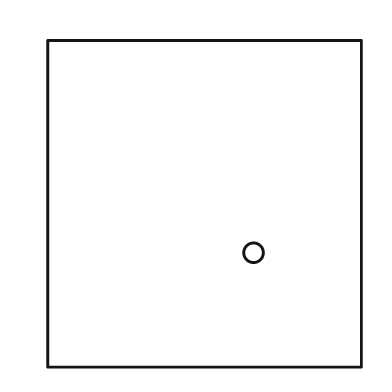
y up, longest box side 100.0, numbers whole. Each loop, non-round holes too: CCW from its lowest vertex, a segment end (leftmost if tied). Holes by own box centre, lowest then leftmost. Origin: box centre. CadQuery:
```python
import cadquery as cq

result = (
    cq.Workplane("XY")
    .moveTo(-48.0, -50.0)
    .lineTo(48.0, -50.0)
    .lineTo(48.0, 50.0)
    .lineTo(-48.0, 50.0)
    .close()
    .moveTo(15.0, -15.0)
    .circle(3.0)
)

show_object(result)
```